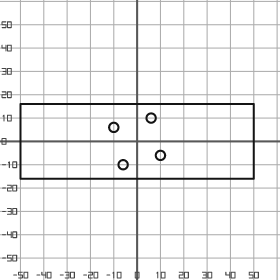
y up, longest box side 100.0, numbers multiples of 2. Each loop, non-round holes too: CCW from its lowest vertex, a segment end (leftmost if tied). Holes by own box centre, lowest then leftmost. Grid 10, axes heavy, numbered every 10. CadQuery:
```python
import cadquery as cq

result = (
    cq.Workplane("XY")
    .moveTo(-50.0, -16.0)
    .lineTo(50.0, -16.0)
    .lineTo(50.0, 16.0)
    .lineTo(-50.0, 16.0)
    .close()
    .moveTo(-6.0, -10.0)
    .circle(2.0)
    .moveTo(10.0, -6.0)
    .circle(2.0)
    .moveTo(-10.0, 6.0)
    .circle(2.0)
    .moveTo(6.0, 10.0)
    .circle(2.0)
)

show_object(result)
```